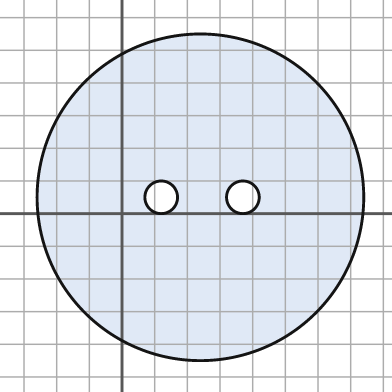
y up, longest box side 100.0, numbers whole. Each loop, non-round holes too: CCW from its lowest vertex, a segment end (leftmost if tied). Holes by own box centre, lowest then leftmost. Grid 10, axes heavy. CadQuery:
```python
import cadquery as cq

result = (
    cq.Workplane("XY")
    .moveTo(24.0, 5.0)
    .circle(50.0)
    .moveTo(12.0, 5.0)
    .circle(5.0)
    .moveTo(37.0, 5.0)
    .circle(5.0)
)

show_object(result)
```